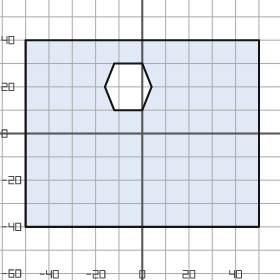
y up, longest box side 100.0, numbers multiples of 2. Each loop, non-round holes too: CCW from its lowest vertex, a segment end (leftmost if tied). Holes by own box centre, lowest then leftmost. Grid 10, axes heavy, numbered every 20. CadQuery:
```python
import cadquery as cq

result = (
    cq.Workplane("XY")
    .moveTo(-50.0, -40.0)
    .lineTo(50.0, -40.0)
    .lineTo(50.0, 40.0)
    .lineTo(-50.0, 40.0)
    .close()
    .moveTo(-12.0, 10.0)
    .lineTo(0.0, 10.0)
    .lineTo(4.0, 20.0)
    .lineTo(0.0, 30.0)
    .lineTo(-12.0, 30.0)
    .lineTo(-16.0, 20.0)
    .close()
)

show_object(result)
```